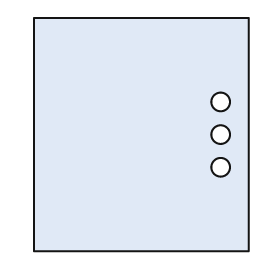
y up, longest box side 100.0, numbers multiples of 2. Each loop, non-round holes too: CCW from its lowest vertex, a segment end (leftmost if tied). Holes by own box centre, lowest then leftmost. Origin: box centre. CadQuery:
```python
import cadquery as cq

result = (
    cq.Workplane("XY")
    .moveTo(-46.0, -50.0)
    .lineTo(46.0, -50.0)
    .lineTo(46.0, 50.0)
    .lineTo(-46.0, 50.0)
    .close()
    .moveTo(34.0, -14.0)
    .circle(4.0)
    .moveTo(34.0, 0.0)
    .circle(4.0)
    .moveTo(34.0, 14.0)
    .circle(4.0)
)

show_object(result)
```